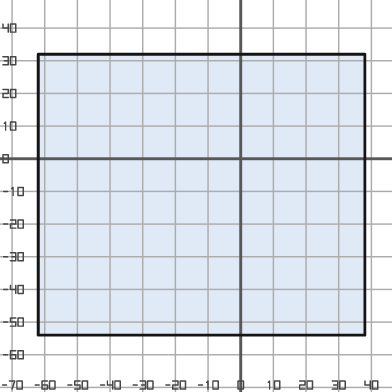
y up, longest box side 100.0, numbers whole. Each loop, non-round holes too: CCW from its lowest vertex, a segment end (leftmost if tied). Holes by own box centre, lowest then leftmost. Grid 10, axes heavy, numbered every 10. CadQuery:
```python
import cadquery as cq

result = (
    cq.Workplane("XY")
    .moveTo(-62.0, -54.0)
    .lineTo(38.0, -54.0)
    .lineTo(38.0, 32.0)
    .lineTo(-62.0, 32.0)
    .close()
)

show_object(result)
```